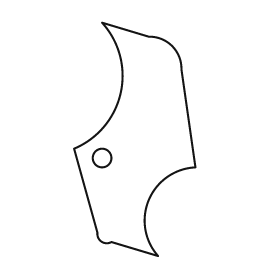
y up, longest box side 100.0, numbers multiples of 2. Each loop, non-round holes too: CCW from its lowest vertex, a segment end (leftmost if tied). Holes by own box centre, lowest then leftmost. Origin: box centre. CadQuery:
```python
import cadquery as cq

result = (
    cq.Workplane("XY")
    .moveTo(10.0, -50.0)
    .threePointArc((6.0, -26.0), (26.0, -12.0))
    .lineTo(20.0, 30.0)
    .threePointArc((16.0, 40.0), (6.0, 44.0))
    .lineTo(-14.0, 50.0)
    .threePointArc((-6.0, 20.0), (-26.0, -4.0))
    .lineTo(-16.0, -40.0)
    .threePointArc((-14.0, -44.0), (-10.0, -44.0))
    .close()
    .moveTo(-14.0, -8.0)
    .circle(4.0)
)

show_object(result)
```